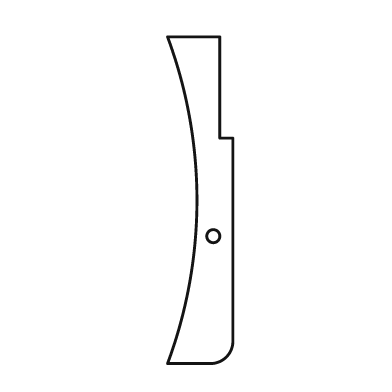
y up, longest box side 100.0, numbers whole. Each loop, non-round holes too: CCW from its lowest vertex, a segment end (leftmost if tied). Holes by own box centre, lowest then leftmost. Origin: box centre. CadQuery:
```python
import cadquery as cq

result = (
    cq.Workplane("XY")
    .moveTo(-10.0, -50.0)
    .lineTo(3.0, -50.0)
    .threePointArc((8.0, -48.0), (10.0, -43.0))
    .lineTo(10.0, 19.0)
    .lineTo(6.0, 19.0)
    .lineTo(6.0, 50.0)
    .lineTo(-10.0, 50.0)
    .threePointArc((-1.0, 0.0), (-10.0, -50.0))
    .close()
    .moveTo(4.0, -11.0)
    .circle(2.0)
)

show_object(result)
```